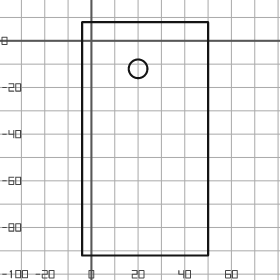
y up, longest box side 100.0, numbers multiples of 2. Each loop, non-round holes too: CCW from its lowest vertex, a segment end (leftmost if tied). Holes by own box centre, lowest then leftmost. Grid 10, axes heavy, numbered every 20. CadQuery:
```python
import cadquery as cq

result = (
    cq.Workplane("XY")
    .moveTo(-4.0, -92.0)
    .lineTo(50.0, -92.0)
    .lineTo(50.0, 8.0)
    .lineTo(-4.0, 8.0)
    .close()
    .moveTo(20.0, -12.0)
    .circle(4.0)
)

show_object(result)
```